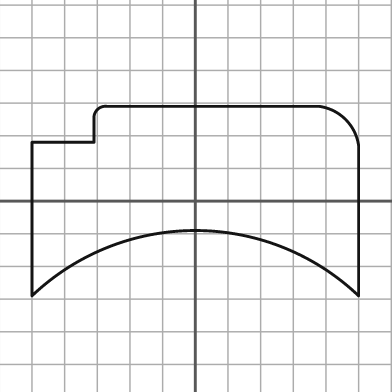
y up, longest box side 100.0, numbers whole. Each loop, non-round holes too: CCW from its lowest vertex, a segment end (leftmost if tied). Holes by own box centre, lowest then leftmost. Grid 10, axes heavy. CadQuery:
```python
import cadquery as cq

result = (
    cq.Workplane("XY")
    .moveTo(-50.0, -29.0)
    .threePointArc((0.0, -9.0), (50.0, -29.0))
    .lineTo(50.0, 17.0)
    .threePointArc((46.0, 25.0), (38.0, 29.0))
    .lineTo(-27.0, 29.0)
    .threePointArc((-30.0, 28.0), (-31.0, 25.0))
    .lineTo(-31.0, 18.0)
    .lineTo(-50.0, 18.0)
    .close()
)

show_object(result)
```